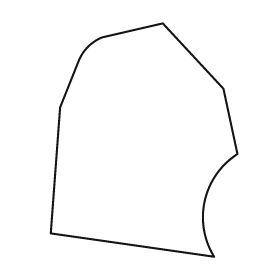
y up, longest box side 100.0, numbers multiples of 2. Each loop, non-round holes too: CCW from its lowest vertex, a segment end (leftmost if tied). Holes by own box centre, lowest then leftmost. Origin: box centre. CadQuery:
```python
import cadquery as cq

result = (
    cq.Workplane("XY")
    .moveTo(30.0, -50.0)
    .threePointArc((26.0, -26.0), (40.0, -6.0))
    .lineTo(34.0, 22.0)
    .lineTo(8.0, 50.0)
    .lineTo(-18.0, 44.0)
    .threePointArc((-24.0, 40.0), (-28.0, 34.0))
    .lineTo(-36.0, 14.0)
    .lineTo(-40.0, -40.0)
    .close()
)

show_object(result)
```